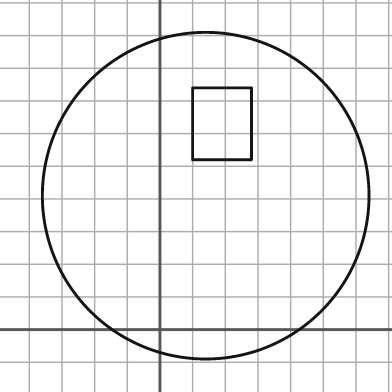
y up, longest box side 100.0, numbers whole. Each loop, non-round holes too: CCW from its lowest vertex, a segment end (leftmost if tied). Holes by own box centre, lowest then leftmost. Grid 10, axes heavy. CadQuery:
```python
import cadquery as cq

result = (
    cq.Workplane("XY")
    .moveTo(14.0, 41.0)
    .circle(50.0)
    .moveTo(10.0, 52.0)
    .lineTo(28.0, 52.0)
    .lineTo(28.0, 74.0)
    .lineTo(10.0, 74.0)
    .close()
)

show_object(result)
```